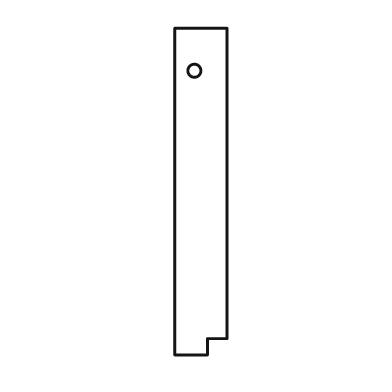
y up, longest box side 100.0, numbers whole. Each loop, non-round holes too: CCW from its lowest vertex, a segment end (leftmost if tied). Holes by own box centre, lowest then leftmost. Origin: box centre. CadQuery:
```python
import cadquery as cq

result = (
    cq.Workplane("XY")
    .moveTo(-8.0, -50.0)
    .lineTo(2.0, -50.0)
    .lineTo(2.0, -45.0)
    .lineTo(8.0, -45.0)
    .lineTo(8.0, 50.0)
    .lineTo(-8.0, 50.0)
    .close()
    .moveTo(-2.0, 37.0)
    .circle(2.0)
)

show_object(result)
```